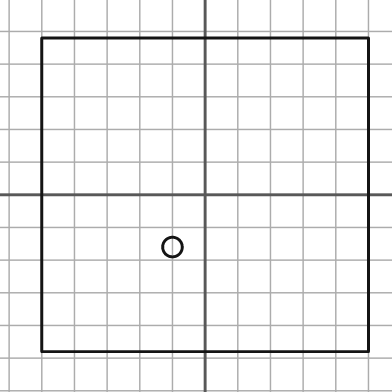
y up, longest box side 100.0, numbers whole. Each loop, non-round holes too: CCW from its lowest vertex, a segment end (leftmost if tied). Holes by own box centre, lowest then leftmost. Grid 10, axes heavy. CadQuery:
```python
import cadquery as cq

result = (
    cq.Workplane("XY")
    .moveTo(-50.0, -48.0)
    .lineTo(50.0, -48.0)
    .lineTo(50.0, 48.0)
    .lineTo(-50.0, 48.0)
    .close()
    .moveTo(-10.0, -16.0)
    .circle(3.0)
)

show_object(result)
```